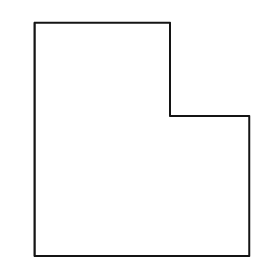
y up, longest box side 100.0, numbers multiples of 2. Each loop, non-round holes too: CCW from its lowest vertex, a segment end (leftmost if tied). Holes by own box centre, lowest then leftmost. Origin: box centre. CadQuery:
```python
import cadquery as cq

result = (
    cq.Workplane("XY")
    .moveTo(-46.0, -50.0)
    .lineTo(46.0, -50.0)
    .lineTo(46.0, 10.0)
    .lineTo(12.0, 10.0)
    .lineTo(12.0, 50.0)
    .lineTo(-46.0, 50.0)
    .close()
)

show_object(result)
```